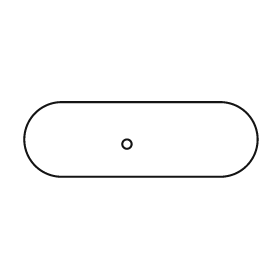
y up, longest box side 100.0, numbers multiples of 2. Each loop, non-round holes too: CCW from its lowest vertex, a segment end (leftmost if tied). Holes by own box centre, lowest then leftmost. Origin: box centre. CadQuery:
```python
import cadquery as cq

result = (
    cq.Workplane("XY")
    .moveTo(-34.0, -16.0)
    .lineTo(34.0, -16.0)
    .threePointArc((50.0, 0.0), (34.0, 16.0))
    .lineTo(-34.0, 16.0)
    .threePointArc((-50.0, 0.0), (-34.0, -16.0))
    .close()
    .moveTo(-6.0, -2.0)
    .circle(2.0)
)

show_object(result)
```